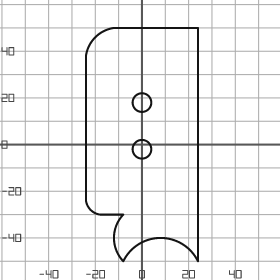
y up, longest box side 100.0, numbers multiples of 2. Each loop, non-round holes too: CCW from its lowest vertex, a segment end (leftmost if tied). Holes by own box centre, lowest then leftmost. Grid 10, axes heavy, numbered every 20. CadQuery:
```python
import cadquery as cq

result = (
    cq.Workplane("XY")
    .moveTo(-8.0, -50.0)
    .threePointArc((8.0, -40.0), (24.0, -50.0))
    .lineTo(24.0, 50.0)
    .lineTo(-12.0, 50.0)
    .threePointArc((-20.0, 46.0), (-24.0, 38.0))
    .lineTo(-24.0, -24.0)
    .threePointArc((-22.0, -28.0), (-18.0, -30.0))
    .lineTo(-8.0, -30.0)
    .threePointArc((-12.0, -40.0), (-8.0, -50.0))
    .close()
    .moveTo(0.0, -2.0)
    .circle(4.0)
    .moveTo(0.0, 18.0)
    .circle(4.0)
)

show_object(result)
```